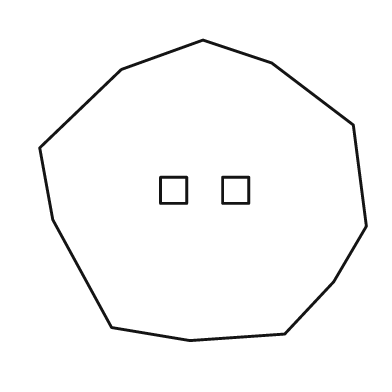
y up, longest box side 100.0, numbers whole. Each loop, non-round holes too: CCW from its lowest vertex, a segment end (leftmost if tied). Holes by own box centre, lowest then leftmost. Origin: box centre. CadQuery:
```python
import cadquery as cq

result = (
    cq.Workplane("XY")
    .moveTo(-4.0, -46.0)
    .lineTo(25.0, -44.0)
    .lineTo(40.0, -28.0)
    .lineTo(50.0, -11.0)
    .lineTo(46.0, 20.0)
    .lineTo(21.0, 39.0)
    .lineTo(0.0, 46.0)
    .lineTo(-25.0, 37.0)
    .lineTo(-50.0, 13.0)
    .lineTo(-46.0, -9.0)
    .lineTo(-28.0, -42.0)
    .close()
    .moveTo(-13.0, -4.0)
    .lineTo(-5.0, -4.0)
    .lineTo(-5.0, 4.0)
    .lineTo(-13.0, 4.0)
    .close()
    .moveTo(6.0, -4.0)
    .lineTo(14.0, -4.0)
    .lineTo(14.0, 4.0)
    .lineTo(6.0, 4.0)
    .close()
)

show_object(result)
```